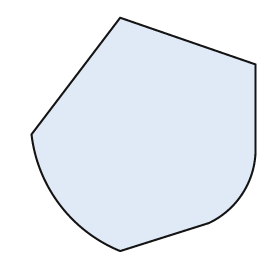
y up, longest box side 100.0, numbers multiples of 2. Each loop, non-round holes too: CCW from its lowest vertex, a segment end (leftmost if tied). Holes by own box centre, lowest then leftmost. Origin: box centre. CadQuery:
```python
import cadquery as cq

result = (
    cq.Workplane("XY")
    .moveTo(-10.0, -50.0)
    .lineTo(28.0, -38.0)
    .threePointArc((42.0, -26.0), (48.0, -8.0))
    .lineTo(48.0, 30.0)
    .lineTo(-10.0, 50.0)
    .lineTo(-48.0, 0.0)
    .threePointArc((-36.0, -30.0), (-10.0, -50.0))
    .close()
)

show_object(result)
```